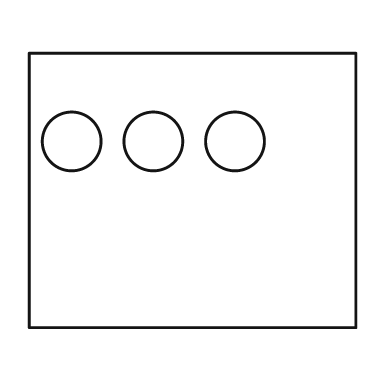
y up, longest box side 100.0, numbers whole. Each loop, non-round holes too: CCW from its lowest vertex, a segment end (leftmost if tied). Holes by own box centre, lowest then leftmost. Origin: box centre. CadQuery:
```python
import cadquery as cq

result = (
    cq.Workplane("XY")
    .moveTo(-50.0, -42.0)
    .lineTo(50.0, -42.0)
    .lineTo(50.0, 42.0)
    .lineTo(-50.0, 42.0)
    .close()
    .moveTo(-37.0, 15.0)
    .circle(9.0)
    .moveTo(-12.0, 15.0)
    .circle(9.0)
    .moveTo(13.0, 15.0)
    .circle(9.0)
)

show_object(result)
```